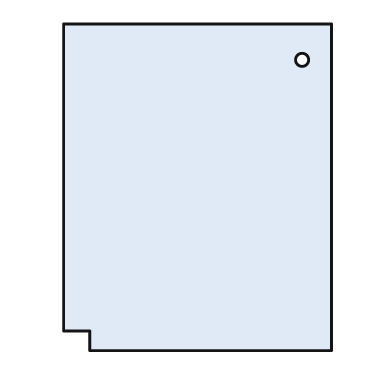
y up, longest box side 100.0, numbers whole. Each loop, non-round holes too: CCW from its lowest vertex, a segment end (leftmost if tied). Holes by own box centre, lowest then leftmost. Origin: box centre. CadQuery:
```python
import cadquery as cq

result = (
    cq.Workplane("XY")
    .moveTo(-33.0, -50.0)
    .lineTo(41.0, -50.0)
    .lineTo(41.0, 50.0)
    .lineTo(-41.0, 50.0)
    .lineTo(-41.0, -44.0)
    .lineTo(-33.0, -44.0)
    .close()
    .moveTo(32.0, 39.0)
    .circle(2.0)
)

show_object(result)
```